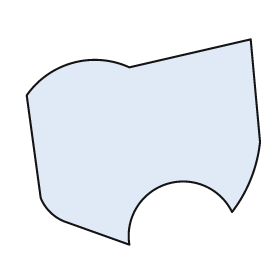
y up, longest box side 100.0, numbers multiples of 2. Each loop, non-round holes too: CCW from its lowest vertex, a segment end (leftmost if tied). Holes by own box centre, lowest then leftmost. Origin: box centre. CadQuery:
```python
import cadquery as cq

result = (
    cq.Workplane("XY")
    .moveTo(-6.0, -44.0)
    .threePointArc((10.0, -18.0), (38.0, -30.0))
    .threePointArc((46.0, -16.0), (50.0, 0.0))
    .lineTo(46.0, 44.0)
    .lineTo(-6.0, 32.0)
    .threePointArc((-30.0, 34.0), (-50.0, 20.0))
    .lineTo(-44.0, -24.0)
    .threePointArc((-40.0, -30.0), (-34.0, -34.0))
    .close()
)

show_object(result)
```